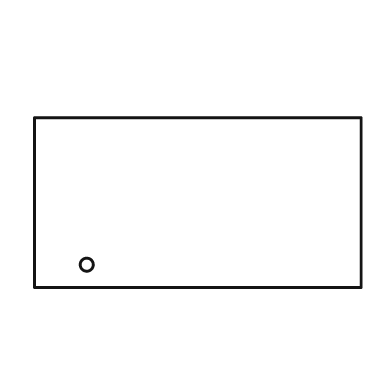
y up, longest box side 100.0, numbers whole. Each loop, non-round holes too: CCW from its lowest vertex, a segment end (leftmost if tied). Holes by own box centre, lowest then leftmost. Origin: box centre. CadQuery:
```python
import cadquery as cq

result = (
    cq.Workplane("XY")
    .moveTo(-50.0, -26.0)
    .lineTo(50.0, -26.0)
    .lineTo(50.0, 26.0)
    .lineTo(-50.0, 26.0)
    .close()
    .moveTo(-34.0, -19.0)
    .circle(2.0)
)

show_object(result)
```